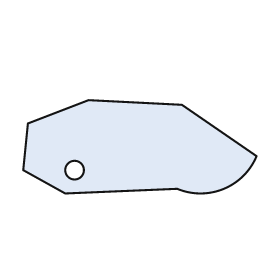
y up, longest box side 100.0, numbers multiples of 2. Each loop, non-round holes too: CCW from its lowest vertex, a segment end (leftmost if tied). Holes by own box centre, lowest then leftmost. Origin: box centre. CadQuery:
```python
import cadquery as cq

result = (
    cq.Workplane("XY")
    .moveTo(-32.0, -20.0)
    .lineTo(16.0, -18.0)
    .threePointArc((36.0, -18.0), (50.0, -4.0))
    .lineTo(18.0, 18.0)
    .lineTo(-22.0, 20.0)
    .lineTo(-48.0, 10.0)
    .lineTo(-50.0, -10.0)
    .close()
    .moveTo(-28.0, -10.0)
    .circle(4.0)
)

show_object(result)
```